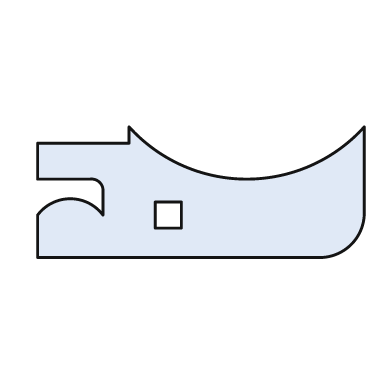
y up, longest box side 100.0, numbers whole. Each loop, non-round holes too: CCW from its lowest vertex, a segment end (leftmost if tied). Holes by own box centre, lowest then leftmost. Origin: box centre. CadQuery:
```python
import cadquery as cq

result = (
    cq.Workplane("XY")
    .moveTo(-50.0, -20.0)
    .lineTo(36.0, -20.0)
    .threePointArc((46.0, -16.0), (50.0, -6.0))
    .lineTo(50.0, 20.0)
    .threePointArc((14.0, 4.0), (-22.0, 20.0))
    .lineTo(-22.0, 15.0)
    .lineTo(-50.0, 15.0)
    .lineTo(-50.0, 4.0)
    .lineTo(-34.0, 4.0)
    .threePointArc((-31.0, 3.0), (-30.0, 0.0))
    .lineTo(-30.0, -7.0)
    .threePointArc((-40.0, -2.0), (-50.0, -7.0))
    .close()
    .moveTo(-14.0, -11.0)
    .lineTo(-6.0, -11.0)
    .lineTo(-6.0, -3.0)
    .lineTo(-14.0, -3.0)
    .close()
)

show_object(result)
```